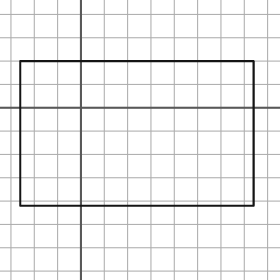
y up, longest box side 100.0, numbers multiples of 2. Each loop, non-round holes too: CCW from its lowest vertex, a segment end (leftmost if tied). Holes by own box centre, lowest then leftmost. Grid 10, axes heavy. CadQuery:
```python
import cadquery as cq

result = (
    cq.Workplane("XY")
    .moveTo(-26.0, -42.0)
    .lineTo(74.0, -42.0)
    .lineTo(74.0, 20.0)
    .lineTo(-26.0, 20.0)
    .close()
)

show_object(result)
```